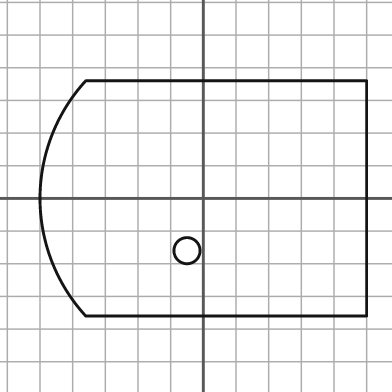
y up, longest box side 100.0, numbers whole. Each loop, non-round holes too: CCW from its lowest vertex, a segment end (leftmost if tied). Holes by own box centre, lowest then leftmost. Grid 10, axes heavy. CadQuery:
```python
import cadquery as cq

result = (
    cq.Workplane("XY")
    .moveTo(-36.0, -36.0)
    .lineTo(50.0, -36.0)
    .lineTo(50.0, 36.0)
    .lineTo(-36.0, 36.0)
    .threePointArc((-50.0, 0.0), (-36.0, -36.0))
    .close()
    .moveTo(-5.0, -16.0)
    .circle(4.0)
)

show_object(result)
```